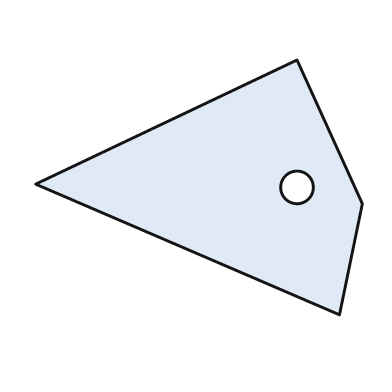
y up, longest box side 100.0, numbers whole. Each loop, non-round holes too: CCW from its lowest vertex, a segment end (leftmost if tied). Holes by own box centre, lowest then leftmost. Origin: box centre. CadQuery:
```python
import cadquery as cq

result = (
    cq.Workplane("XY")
    .moveTo(43.0, -39.0)
    .lineTo(50.0, -5.0)
    .lineTo(30.0, 39.0)
    .lineTo(-50.0, 1.0)
    .close()
    .moveTo(30.0, 0.0)
    .circle(5.0)
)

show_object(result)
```